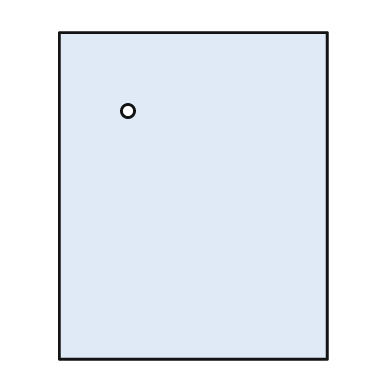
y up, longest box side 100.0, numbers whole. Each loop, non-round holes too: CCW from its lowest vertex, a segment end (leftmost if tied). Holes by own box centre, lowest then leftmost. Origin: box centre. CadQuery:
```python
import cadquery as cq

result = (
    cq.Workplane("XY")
    .moveTo(-41.0, -50.0)
    .lineTo(41.0, -50.0)
    .lineTo(41.0, 50.0)
    .lineTo(-41.0, 50.0)
    .close()
    .moveTo(-20.0, 26.0)
    .circle(2.0)
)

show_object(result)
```